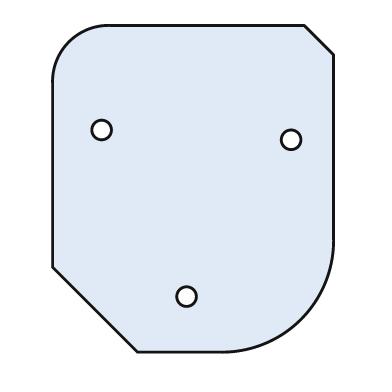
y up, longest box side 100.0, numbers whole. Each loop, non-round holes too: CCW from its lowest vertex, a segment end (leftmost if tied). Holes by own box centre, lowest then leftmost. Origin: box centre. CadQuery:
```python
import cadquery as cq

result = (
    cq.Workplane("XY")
    .moveTo(-17.0, -50.0)
    .lineTo(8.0, -50.0)
    .threePointArc((33.0, -40.0), (43.0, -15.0))
    .lineTo(43.0, 41.0)
    .lineTo(34.0, 50.0)
    .lineTo(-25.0, 50.0)
    .threePointArc((-38.0, 45.0), (-43.0, 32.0))
    .lineTo(-43.0, -24.0)
    .close()
    .moveTo(-2.0, -33.0)
    .circle(3.0)
    .moveTo(30.0, 15.0)
    .circle(3.0)
    .moveTo(-28.0, 18.0)
    .circle(3.0)
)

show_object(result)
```